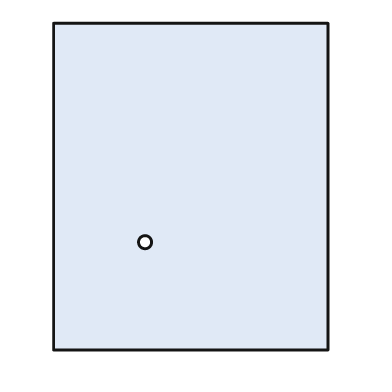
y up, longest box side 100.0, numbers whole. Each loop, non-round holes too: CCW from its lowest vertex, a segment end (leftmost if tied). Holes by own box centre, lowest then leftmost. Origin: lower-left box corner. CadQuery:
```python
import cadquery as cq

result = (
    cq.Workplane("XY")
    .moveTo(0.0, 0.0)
    .lineTo(84.0, 0.0)
    .lineTo(84.0, 100.0)
    .lineTo(0.0, 100.0)
    .close()
    .moveTo(28.0, 33.0)
    .circle(2.0)
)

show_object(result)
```